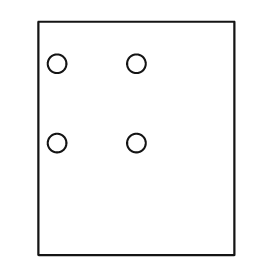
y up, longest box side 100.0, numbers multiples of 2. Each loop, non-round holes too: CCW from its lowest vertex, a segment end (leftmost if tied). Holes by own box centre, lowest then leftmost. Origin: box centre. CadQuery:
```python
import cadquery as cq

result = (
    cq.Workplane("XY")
    .moveTo(-42.0, -50.0)
    .lineTo(42.0, -50.0)
    .lineTo(42.0, 50.0)
    .lineTo(-42.0, 50.0)
    .close()
    .moveTo(-34.0, -2.0)
    .circle(4.0)
    .moveTo(0.0, -2.0)
    .circle(4.0)
    .moveTo(-34.0, 32.0)
    .circle(4.0)
    .moveTo(0.0, 32.0)
    .circle(4.0)
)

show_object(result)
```